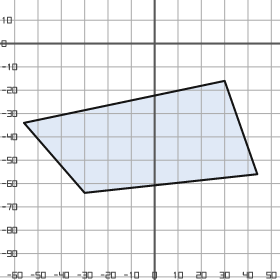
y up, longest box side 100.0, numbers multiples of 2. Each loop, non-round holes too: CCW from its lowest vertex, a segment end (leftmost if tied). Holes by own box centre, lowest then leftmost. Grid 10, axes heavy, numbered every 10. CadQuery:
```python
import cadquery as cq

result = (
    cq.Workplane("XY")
    .moveTo(-30.0, -64.0)
    .lineTo(44.0, -56.0)
    .lineTo(30.0, -16.0)
    .lineTo(-56.0, -34.0)
    .close()
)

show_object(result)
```